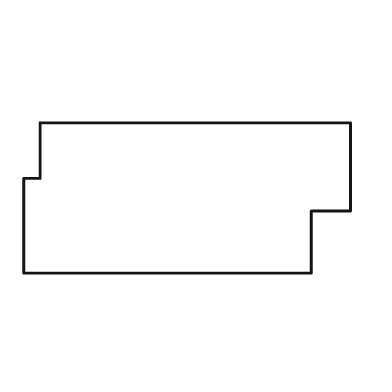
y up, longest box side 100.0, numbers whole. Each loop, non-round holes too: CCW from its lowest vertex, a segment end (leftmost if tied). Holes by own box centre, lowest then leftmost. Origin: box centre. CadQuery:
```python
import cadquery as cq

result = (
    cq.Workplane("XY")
    .moveTo(-50.0, -23.0)
    .lineTo(38.0, -23.0)
    .lineTo(38.0, -4.0)
    .lineTo(50.0, -4.0)
    .lineTo(50.0, 23.0)
    .lineTo(-45.0, 23.0)
    .lineTo(-45.0, 6.0)
    .lineTo(-50.0, 6.0)
    .close()
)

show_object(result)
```